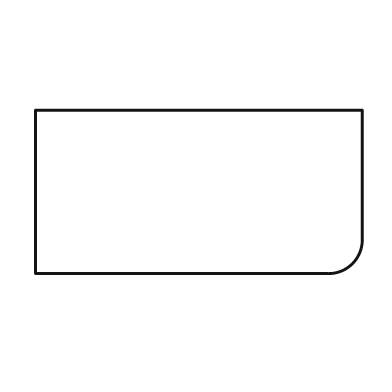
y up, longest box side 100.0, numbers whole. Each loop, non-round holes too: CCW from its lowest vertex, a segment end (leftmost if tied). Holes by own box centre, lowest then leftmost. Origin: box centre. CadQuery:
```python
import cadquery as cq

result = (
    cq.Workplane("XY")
    .moveTo(-50.0, -25.0)
    .lineTo(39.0, -25.0)
    .threePointArc((47.0, -22.0), (50.0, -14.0))
    .lineTo(50.0, 25.0)
    .lineTo(-50.0, 25.0)
    .close()
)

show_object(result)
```